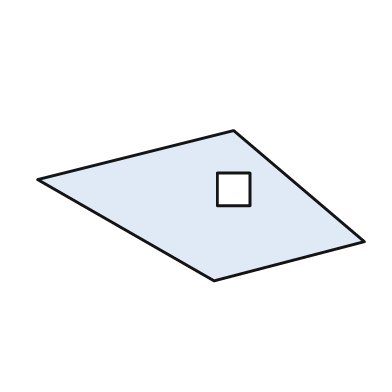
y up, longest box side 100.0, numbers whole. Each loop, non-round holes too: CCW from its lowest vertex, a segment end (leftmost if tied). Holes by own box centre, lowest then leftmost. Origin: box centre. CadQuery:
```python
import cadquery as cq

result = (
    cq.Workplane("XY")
    .moveTo(4.0, -23.0)
    .lineTo(50.0, -11.0)
    .lineTo(10.0, 23.0)
    .lineTo(-50.0, 8.0)
    .close()
    .moveTo(5.0, 0.0)
    .lineTo(15.0, 0.0)
    .lineTo(15.0, 10.0)
    .lineTo(5.0, 10.0)
    .close()
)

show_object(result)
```